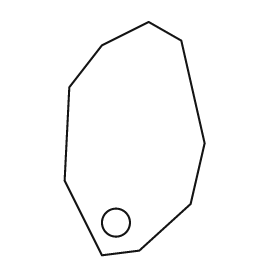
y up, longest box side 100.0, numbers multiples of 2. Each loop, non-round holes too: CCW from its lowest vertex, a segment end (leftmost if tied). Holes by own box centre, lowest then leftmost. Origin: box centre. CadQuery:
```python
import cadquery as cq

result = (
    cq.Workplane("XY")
    .moveTo(-14.0, -50.0)
    .lineTo(2.0, -48.0)
    .lineTo(24.0, -28.0)
    .lineTo(30.0, -2.0)
    .lineTo(20.0, 42.0)
    .lineTo(6.0, 50.0)
    .lineTo(-14.0, 40.0)
    .lineTo(-28.0, 22.0)
    .lineTo(-30.0, -18.0)
    .close()
    .moveTo(-8.0, -36.0)
    .circle(6.0)
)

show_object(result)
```